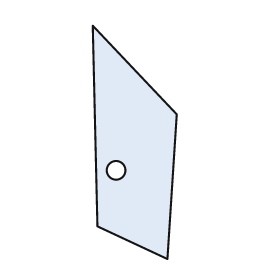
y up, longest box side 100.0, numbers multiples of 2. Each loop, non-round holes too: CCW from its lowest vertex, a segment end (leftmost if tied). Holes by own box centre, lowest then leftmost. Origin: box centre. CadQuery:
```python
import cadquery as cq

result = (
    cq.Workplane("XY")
    .moveTo(14.0, -50.0)
    .lineTo(18.0, 12.0)
    .lineTo(-18.0, 50.0)
    .lineTo(-16.0, -36.0)
    .close()
    .moveTo(-8.0, -12.0)
    .circle(4.0)
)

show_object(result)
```